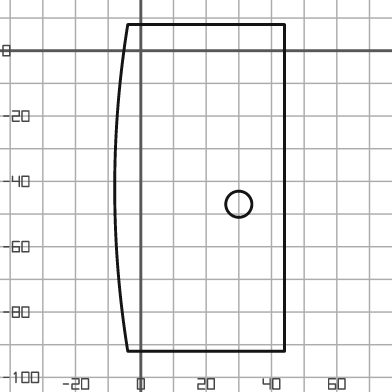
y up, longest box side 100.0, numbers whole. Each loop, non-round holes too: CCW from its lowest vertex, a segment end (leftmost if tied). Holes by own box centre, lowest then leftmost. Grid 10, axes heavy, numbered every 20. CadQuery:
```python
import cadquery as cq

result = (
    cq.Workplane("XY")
    .moveTo(-4.0, -92.0)
    .lineTo(44.0, -92.0)
    .lineTo(44.0, 8.0)
    .lineTo(-4.0, 8.0)
    .threePointArc((-8.0, -42.0), (-4.0, -92.0))
    .close()
    .moveTo(30.0, -47.0)
    .circle(4.0)
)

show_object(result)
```